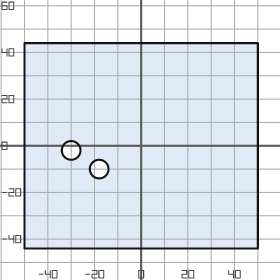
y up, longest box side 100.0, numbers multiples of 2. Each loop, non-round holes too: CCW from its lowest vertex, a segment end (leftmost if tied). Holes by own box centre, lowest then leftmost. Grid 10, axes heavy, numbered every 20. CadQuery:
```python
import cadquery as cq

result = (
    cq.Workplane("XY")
    .moveTo(-50.0, -44.0)
    .lineTo(50.0, -44.0)
    .lineTo(50.0, 44.0)
    .lineTo(-50.0, 44.0)
    .close()
    .moveTo(-18.0, -10.0)
    .circle(4.0)
    .moveTo(-30.0, -2.0)
    .circle(4.0)
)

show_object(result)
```